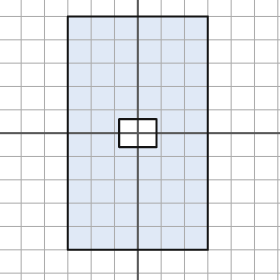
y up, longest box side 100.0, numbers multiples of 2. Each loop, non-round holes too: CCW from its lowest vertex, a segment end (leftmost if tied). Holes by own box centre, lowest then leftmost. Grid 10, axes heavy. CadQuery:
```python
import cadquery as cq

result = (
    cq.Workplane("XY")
    .moveTo(-30.0, -50.0)
    .lineTo(30.0, -50.0)
    .lineTo(30.0, 50.0)
    .lineTo(-30.0, 50.0)
    .close()
    .moveTo(-8.0, -6.0)
    .lineTo(8.0, -6.0)
    .lineTo(8.0, 6.0)
    .lineTo(-8.0, 6.0)
    .close()
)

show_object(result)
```